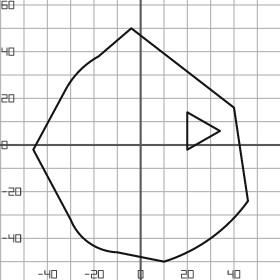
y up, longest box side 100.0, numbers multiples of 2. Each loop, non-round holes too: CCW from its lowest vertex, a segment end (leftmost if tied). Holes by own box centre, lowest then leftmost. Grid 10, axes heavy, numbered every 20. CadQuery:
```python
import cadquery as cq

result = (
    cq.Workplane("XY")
    .moveTo(10.0, -50.0)
    .threePointArc((30.0, -40.0), (46.0, -24.0))
    .lineTo(40.0, 16.0)
    .lineTo(-4.0, 50.0)
    .lineTo(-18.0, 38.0)
    .threePointArc((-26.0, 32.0), (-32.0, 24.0))
    .lineTo(-46.0, -2.0)
    .lineTo(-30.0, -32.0)
    .threePointArc((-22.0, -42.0), (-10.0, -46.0))
    .close()
    .moveTo(20.0, -2.0)
    .lineTo(34.0, 6.0)
    .lineTo(20.0, 14.0)
    .close()
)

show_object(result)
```